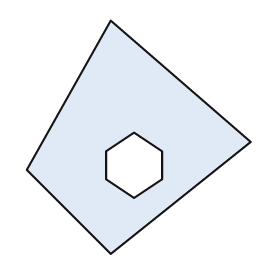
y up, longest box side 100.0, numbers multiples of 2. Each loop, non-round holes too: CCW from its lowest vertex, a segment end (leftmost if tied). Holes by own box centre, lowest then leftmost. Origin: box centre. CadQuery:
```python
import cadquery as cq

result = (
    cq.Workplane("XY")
    .moveTo(-12.0, -50.0)
    .lineTo(48.0, -2.0)
    .lineTo(-12.0, 50.0)
    .lineTo(-48.0, -14.0)
    .close()
    .moveTo(-2.0, -26.0)
    .lineTo(10.0, -18.0)
    .lineTo(10.0, -6.0)
    .lineTo(-2.0, 2.0)
    .lineTo(-14.0, -6.0)
    .lineTo(-14.0, -18.0)
    .close()
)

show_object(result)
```